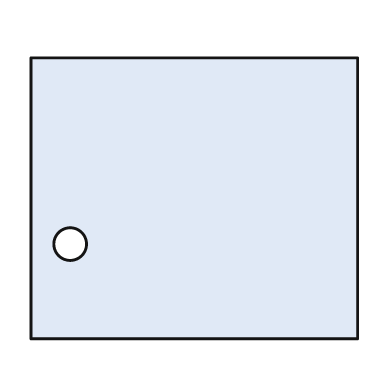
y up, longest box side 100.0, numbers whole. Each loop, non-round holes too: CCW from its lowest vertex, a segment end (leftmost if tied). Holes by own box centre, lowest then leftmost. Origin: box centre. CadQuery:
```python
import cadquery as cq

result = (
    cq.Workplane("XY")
    .moveTo(-50.0, -43.0)
    .lineTo(50.0, -43.0)
    .lineTo(50.0, 43.0)
    .lineTo(-50.0, 43.0)
    .close()
    .moveTo(-38.0, -14.0)
    .circle(5.0)
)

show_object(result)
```